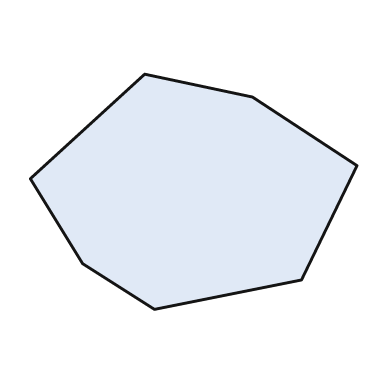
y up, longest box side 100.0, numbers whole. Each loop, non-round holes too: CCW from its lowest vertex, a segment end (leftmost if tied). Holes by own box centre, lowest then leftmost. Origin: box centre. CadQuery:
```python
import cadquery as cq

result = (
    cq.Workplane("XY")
    .moveTo(-12.0, -36.0)
    .lineTo(33.0, -27.0)
    .lineTo(50.0, 8.0)
    .lineTo(18.0, 29.0)
    .lineTo(-15.0, 36.0)
    .lineTo(-50.0, 4.0)
    .lineTo(-34.0, -22.0)
    .close()
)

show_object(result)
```